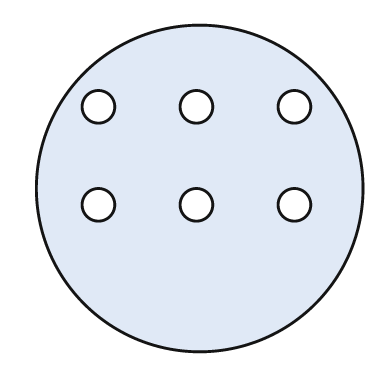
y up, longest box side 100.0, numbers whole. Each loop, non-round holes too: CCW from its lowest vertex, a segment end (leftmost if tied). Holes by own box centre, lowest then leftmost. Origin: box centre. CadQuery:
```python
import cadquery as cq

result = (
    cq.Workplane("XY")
    .moveTo(0.0, 0.0)
    .circle(50.0)
    .moveTo(-31.0, -5.0)
    .circle(5.0)
    .moveTo(-1.0, -5.0)
    .circle(5.0)
    .moveTo(29.0, -5.0)
    .circle(5.0)
    .moveTo(-31.0, 25.0)
    .circle(5.0)
    .moveTo(-1.0, 25.0)
    .circle(5.0)
    .moveTo(29.0, 25.0)
    .circle(5.0)
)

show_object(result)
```